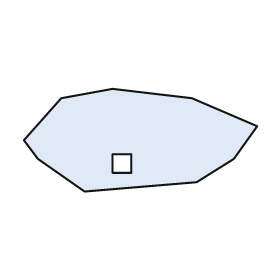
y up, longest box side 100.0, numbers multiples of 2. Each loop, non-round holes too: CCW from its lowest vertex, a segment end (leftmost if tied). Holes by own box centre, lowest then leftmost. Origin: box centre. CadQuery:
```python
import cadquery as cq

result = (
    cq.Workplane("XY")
    .moveTo(-24.0, -22.0)
    .lineTo(24.0, -18.0)
    .lineTo(40.0, -8.0)
    .lineTo(50.0, 6.0)
    .lineTo(22.0, 18.0)
    .lineTo(-12.0, 22.0)
    .lineTo(-34.0, 18.0)
    .lineTo(-50.0, 0.0)
    .lineTo(-44.0, -8.0)
    .close()
    .moveTo(-12.0, -14.0)
    .lineTo(-4.0, -14.0)
    .lineTo(-4.0, -6.0)
    .lineTo(-12.0, -6.0)
    .close()
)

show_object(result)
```